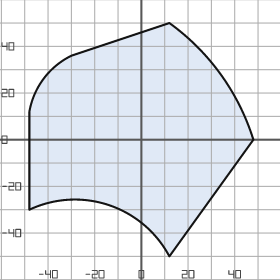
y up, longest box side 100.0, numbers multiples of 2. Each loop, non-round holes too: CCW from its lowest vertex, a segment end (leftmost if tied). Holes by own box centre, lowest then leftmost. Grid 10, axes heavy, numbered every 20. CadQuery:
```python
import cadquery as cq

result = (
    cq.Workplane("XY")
    .moveTo(12.0, -50.0)
    .lineTo(48.0, 0.0)
    .threePointArc((34.0, 28.0), (12.0, 50.0))
    .lineTo(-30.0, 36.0)
    .threePointArc((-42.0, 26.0), (-48.0, 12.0))
    .lineTo(-48.0, -30.0)
    .threePointArc((-14.0, -28.0), (12.0, -50.0))
    .close()
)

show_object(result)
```